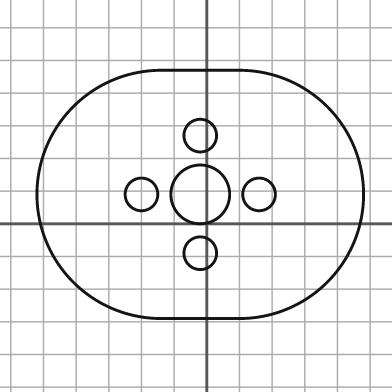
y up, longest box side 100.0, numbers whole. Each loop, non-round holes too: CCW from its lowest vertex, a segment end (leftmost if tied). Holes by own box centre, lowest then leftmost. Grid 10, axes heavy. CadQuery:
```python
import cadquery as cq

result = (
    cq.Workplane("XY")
    .moveTo(-14.0, -29.0)
    .lineTo(10.0, -29.0)
    .threePointArc((48.0, 9.0), (10.0, 47.0))
    .lineTo(-14.0, 47.0)
    .threePointArc((-52.0, 9.0), (-14.0, -29.0))
    .close()
    .moveTo(-2.0, -9.0)
    .circle(5.0)
    .moveTo(-20.0, 9.0)
    .circle(5.0)
    .moveTo(-2.0, 9.0)
    .circle(9.0)
    .moveTo(16.0, 9.0)
    .circle(5.0)
    .moveTo(-2.0, 27.0)
    .circle(5.0)
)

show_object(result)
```